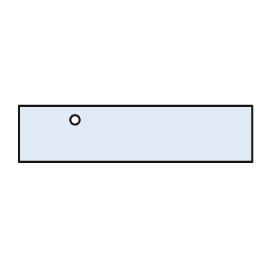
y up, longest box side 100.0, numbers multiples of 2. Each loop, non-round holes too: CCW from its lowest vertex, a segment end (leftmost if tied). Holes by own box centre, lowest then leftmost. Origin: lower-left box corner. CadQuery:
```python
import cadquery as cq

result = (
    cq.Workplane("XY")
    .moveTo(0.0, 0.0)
    .lineTo(100.0, 0.0)
    .lineTo(100.0, 24.0)
    .lineTo(0.0, 24.0)
    .close()
    .moveTo(24.0, 18.0)
    .circle(2.0)
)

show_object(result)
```